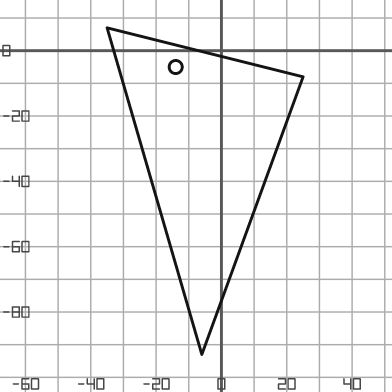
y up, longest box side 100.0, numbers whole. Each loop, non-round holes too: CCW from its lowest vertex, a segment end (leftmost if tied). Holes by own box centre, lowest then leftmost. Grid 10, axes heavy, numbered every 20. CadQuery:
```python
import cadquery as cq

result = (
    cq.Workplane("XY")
    .moveTo(-6.0, -93.0)
    .lineTo(25.0, -8.0)
    .lineTo(-35.0, 7.0)
    .close()
    .moveTo(-14.0, -5.0)
    .circle(2.0)
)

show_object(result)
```